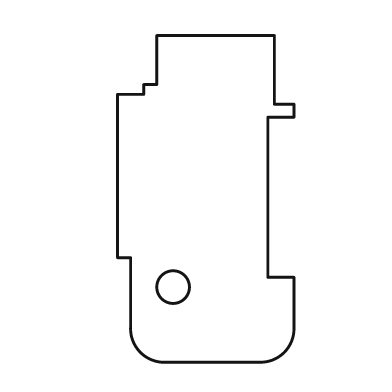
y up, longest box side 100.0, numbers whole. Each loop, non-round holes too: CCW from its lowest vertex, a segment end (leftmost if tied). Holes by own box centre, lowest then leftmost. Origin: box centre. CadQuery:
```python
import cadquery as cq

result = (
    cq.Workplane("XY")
    .moveTo(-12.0, -50.0)
    .lineTo(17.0, -50.0)
    .threePointArc((24.0, -47.0), (27.0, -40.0))
    .lineTo(27.0, -24.0)
    .lineTo(19.0, -24.0)
    .lineTo(19.0, 25.0)
    .lineTo(27.0, 25.0)
    .lineTo(27.0, 29.0)
    .lineTo(21.0, 29.0)
    .lineTo(21.0, 50.0)
    .lineTo(-15.0, 50.0)
    .lineTo(-15.0, 35.0)
    .lineTo(-19.0, 35.0)
    .lineTo(-19.0, 32.0)
    .lineTo(-27.0, 32.0)
    .lineTo(-27.0, -18.0)
    .lineTo(-23.0, -18.0)
    .lineTo(-23.0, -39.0)
    .threePointArc((-20.0, -47.0), (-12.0, -50.0))
    .close()
    .moveTo(-10.0, -27.0)
    .circle(5.0)
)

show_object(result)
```